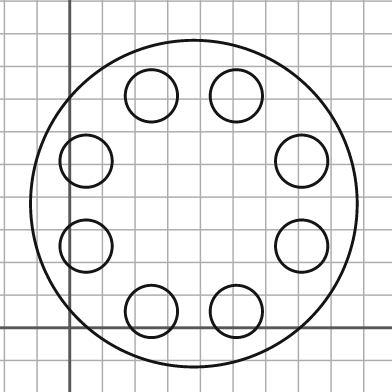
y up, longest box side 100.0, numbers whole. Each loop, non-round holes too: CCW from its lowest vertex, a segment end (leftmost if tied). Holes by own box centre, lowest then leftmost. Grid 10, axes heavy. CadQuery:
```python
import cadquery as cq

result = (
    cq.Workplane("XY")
    .moveTo(38.0, 38.0)
    .circle(50.0)
    .moveTo(25.0, 5.0)
    .circle(8.0)
    .moveTo(51.0, 5.0)
    .circle(8.0)
    .moveTo(5.0, 25.0)
    .circle(8.0)
    .moveTo(71.0, 25.0)
    .circle(8.0)
    .moveTo(5.0, 51.0)
    .circle(8.0)
    .moveTo(71.0, 51.0)
    .circle(8.0)
    .moveTo(25.0, 71.0)
    .circle(8.0)
    .moveTo(51.0, 71.0)
    .circle(8.0)
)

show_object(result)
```